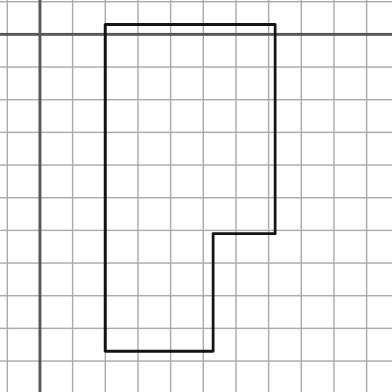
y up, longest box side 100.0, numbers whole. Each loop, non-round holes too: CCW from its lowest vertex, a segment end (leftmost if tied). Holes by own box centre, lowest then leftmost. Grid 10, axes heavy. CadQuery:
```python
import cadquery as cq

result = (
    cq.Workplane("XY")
    .moveTo(20.0, -97.0)
    .lineTo(53.0, -97.0)
    .lineTo(53.0, -61.0)
    .lineTo(72.0, -61.0)
    .lineTo(72.0, 3.0)
    .lineTo(20.0, 3.0)
    .close()
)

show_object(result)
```